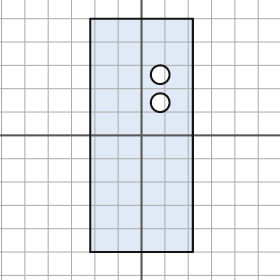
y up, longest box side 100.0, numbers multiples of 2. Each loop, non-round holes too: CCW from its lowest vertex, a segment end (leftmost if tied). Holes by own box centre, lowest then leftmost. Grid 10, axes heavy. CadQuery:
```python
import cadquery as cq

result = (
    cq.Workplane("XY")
    .moveTo(-22.0, -50.0)
    .lineTo(22.0, -50.0)
    .lineTo(22.0, 50.0)
    .lineTo(-22.0, 50.0)
    .close()
    .moveTo(8.0, 14.0)
    .circle(4.0)
    .moveTo(8.0, 26.0)
    .circle(4.0)
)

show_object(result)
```